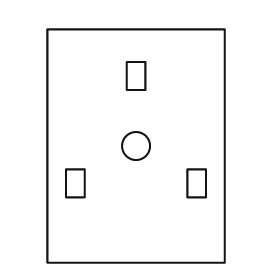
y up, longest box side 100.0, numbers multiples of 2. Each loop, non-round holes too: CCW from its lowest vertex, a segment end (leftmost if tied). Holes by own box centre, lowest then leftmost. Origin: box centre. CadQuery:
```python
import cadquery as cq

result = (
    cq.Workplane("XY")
    .moveTo(-38.0, -50.0)
    .lineTo(38.0, -50.0)
    .lineTo(38.0, 50.0)
    .lineTo(-38.0, 50.0)
    .close()
    .moveTo(-30.0, -22.0)
    .lineTo(-22.0, -22.0)
    .lineTo(-22.0, -10.0)
    .lineTo(-30.0, -10.0)
    .close()
    .moveTo(22.0, -22.0)
    .lineTo(30.0, -22.0)
    .lineTo(30.0, -10.0)
    .lineTo(22.0, -10.0)
    .close()
    .moveTo(0.0, 0.0)
    .circle(6.0)
    .moveTo(-4.0, 24.0)
    .lineTo(4.0, 24.0)
    .lineTo(4.0, 36.0)
    .lineTo(-4.0, 36.0)
    .close()
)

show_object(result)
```